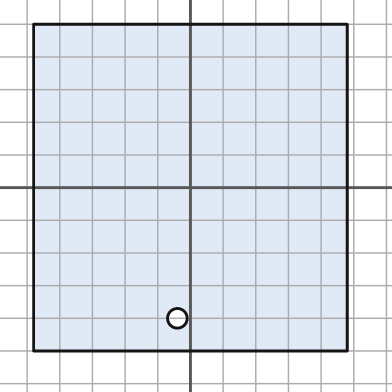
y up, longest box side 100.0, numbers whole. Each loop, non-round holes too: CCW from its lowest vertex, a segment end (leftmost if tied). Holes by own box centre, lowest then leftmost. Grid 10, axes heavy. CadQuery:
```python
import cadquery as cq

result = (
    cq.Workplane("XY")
    .moveTo(-48.0, -50.0)
    .lineTo(48.0, -50.0)
    .lineTo(48.0, 50.0)
    .lineTo(-48.0, 50.0)
    .close()
    .moveTo(-4.0, -40.0)
    .circle(3.0)
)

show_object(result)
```